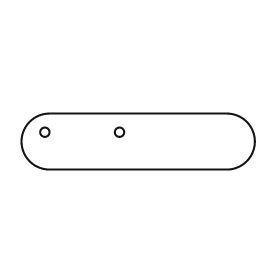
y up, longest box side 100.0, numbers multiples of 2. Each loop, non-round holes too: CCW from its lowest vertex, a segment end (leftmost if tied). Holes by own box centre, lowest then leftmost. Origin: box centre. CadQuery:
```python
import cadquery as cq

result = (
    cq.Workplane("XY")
    .moveTo(-38.0, -12.0)
    .lineTo(38.0, -12.0)
    .threePointArc((50.0, 0.0), (38.0, 12.0))
    .lineTo(-38.0, 12.0)
    .threePointArc((-50.0, 0.0), (-38.0, -12.0))
    .close()
    .moveTo(-40.0, 4.0)
    .circle(2.0)
    .moveTo(-8.0, 4.0)
    .circle(2.0)
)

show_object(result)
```